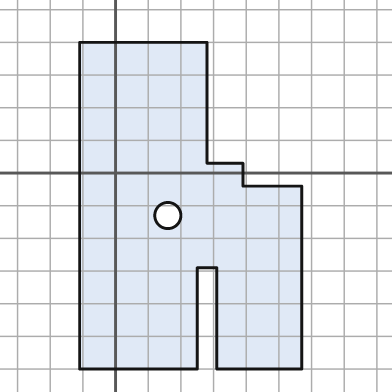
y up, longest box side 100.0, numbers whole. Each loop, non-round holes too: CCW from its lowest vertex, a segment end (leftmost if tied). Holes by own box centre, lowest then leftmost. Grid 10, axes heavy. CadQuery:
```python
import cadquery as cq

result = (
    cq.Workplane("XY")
    .moveTo(-11.0, -60.0)
    .lineTo(25.0, -60.0)
    .lineTo(25.0, -29.0)
    .lineTo(31.0, -29.0)
    .lineTo(31.0, -60.0)
    .lineTo(57.0, -60.0)
    .lineTo(57.0, -4.0)
    .lineTo(39.0, -4.0)
    .lineTo(39.0, 3.0)
    .lineTo(28.0, 3.0)
    .lineTo(28.0, 40.0)
    .lineTo(-11.0, 40.0)
    .close()
    .moveTo(16.0, -13.0)
    .circle(4.0)
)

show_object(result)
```